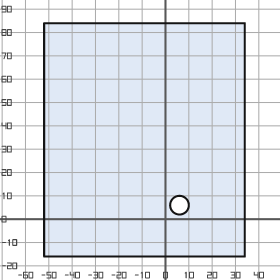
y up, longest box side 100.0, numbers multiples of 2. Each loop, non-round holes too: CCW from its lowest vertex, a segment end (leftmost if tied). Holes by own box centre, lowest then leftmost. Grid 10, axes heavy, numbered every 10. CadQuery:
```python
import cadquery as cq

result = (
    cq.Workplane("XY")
    .moveTo(-52.0, -16.0)
    .lineTo(34.0, -16.0)
    .lineTo(34.0, 84.0)
    .lineTo(-52.0, 84.0)
    .close()
    .moveTo(6.0, 6.0)
    .circle(4.0)
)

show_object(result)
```